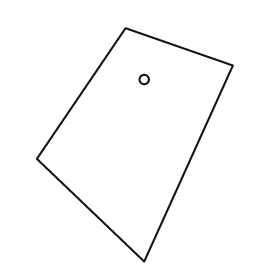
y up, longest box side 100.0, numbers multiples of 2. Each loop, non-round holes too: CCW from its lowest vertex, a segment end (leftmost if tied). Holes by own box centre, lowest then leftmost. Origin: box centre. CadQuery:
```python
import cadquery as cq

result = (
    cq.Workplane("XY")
    .moveTo(4.0, -50.0)
    .lineTo(42.0, 34.0)
    .lineTo(-4.0, 50.0)
    .lineTo(-42.0, -6.0)
    .close()
    .moveTo(4.0, 28.0)
    .circle(2.0)
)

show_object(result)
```